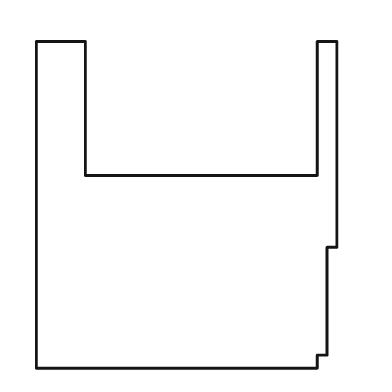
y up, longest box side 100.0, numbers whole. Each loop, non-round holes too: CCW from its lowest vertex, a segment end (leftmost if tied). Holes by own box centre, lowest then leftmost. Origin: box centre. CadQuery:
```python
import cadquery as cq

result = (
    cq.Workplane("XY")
    .moveTo(-46.0, -50.0)
    .lineTo(40.0, -50.0)
    .lineTo(40.0, -46.0)
    .lineTo(43.0, -46.0)
    .lineTo(43.0, -13.0)
    .lineTo(46.0, -13.0)
    .lineTo(46.0, 50.0)
    .lineTo(40.0, 50.0)
    .lineTo(40.0, 9.0)
    .lineTo(-31.0, 9.0)
    .lineTo(-31.0, 50.0)
    .lineTo(-46.0, 50.0)
    .close()
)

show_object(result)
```